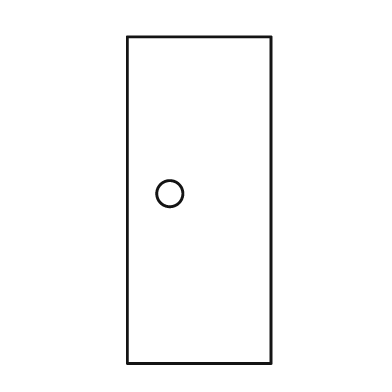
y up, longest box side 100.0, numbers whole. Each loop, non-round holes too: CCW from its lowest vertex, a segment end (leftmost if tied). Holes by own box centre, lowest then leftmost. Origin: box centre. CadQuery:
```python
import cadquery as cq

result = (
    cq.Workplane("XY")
    .moveTo(-22.0, -50.0)
    .lineTo(22.0, -50.0)
    .lineTo(22.0, 50.0)
    .lineTo(-22.0, 50.0)
    .close()
    .moveTo(-9.0, 2.0)
    .circle(4.0)
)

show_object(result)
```